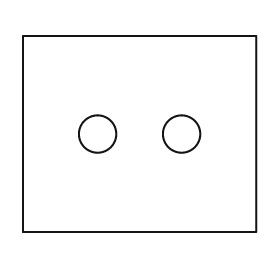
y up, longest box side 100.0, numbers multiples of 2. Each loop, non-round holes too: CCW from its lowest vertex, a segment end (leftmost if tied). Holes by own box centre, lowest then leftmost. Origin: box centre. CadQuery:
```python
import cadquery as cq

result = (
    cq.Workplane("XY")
    .moveTo(-50.0, -42.0)
    .lineTo(50.0, -42.0)
    .lineTo(50.0, 42.0)
    .lineTo(-50.0, 42.0)
    .close()
    .moveTo(-18.0, 0.0)
    .circle(8.0)
    .moveTo(18.0, 0.0)
    .circle(8.0)
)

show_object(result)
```